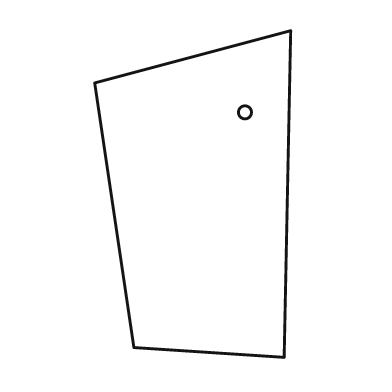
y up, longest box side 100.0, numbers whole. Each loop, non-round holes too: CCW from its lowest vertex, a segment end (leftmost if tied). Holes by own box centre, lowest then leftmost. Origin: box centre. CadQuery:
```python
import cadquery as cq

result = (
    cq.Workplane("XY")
    .moveTo(28.0, -50.0)
    .lineTo(30.0, 50.0)
    .lineTo(-30.0, 34.0)
    .lineTo(-18.0, -47.0)
    .close()
    .moveTo(16.0, 25.0)
    .circle(2.0)
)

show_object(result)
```